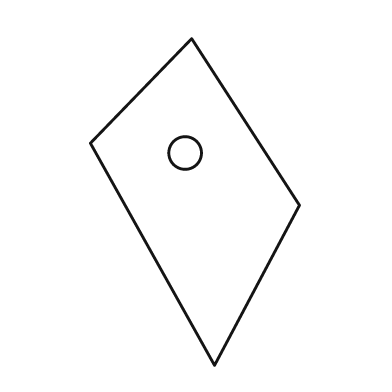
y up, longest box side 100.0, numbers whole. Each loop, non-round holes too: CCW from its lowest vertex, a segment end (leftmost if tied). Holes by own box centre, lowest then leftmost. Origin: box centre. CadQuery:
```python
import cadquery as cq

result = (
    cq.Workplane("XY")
    .moveTo(6.0, -50.0)
    .lineTo(32.0, -1.0)
    .lineTo(-1.0, 50.0)
    .lineTo(-32.0, 18.0)
    .close()
    .moveTo(-3.0, 15.0)
    .circle(5.0)
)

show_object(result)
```